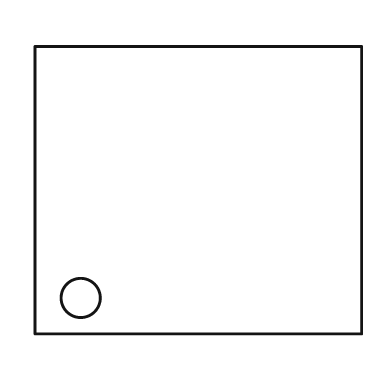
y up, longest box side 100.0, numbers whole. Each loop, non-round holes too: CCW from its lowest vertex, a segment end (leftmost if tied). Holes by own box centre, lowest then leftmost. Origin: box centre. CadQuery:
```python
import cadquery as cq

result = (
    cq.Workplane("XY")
    .moveTo(-50.0, -44.0)
    .lineTo(50.0, -44.0)
    .lineTo(50.0, 44.0)
    .lineTo(-50.0, 44.0)
    .close()
    .moveTo(-36.0, -33.0)
    .circle(6.0)
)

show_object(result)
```